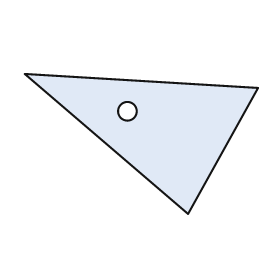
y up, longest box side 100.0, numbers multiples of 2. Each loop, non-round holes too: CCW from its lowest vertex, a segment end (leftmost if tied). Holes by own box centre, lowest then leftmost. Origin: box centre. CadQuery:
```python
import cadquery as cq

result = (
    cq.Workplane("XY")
    .moveTo(20.0, -30.0)
    .lineTo(50.0, 24.0)
    .lineTo(-50.0, 30.0)
    .close()
    .moveTo(-6.0, 14.0)
    .circle(4.0)
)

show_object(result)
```